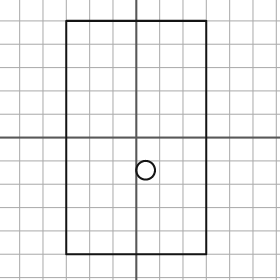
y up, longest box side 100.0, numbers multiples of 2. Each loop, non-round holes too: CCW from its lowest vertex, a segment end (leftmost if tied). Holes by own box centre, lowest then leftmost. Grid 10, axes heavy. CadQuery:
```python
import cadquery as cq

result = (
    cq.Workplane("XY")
    .moveTo(-30.0, -50.0)
    .lineTo(30.0, -50.0)
    .lineTo(30.0, 50.0)
    .lineTo(-30.0, 50.0)
    .close()
    .moveTo(4.0, -14.0)
    .circle(4.0)
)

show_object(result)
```